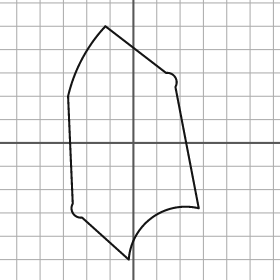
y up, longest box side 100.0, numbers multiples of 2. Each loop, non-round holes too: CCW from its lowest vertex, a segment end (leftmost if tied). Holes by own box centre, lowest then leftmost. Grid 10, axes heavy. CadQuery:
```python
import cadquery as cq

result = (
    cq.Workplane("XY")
    .moveTo(-2.0, -50.0)
    .threePointArc((8.0, -32.0), (28.0, -28.0))
    .lineTo(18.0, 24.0)
    .threePointArc((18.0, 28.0), (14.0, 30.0))
    .lineTo(-12.0, 50.0)
    .threePointArc((-22.0, 36.0), (-28.0, 20.0))
    .lineTo(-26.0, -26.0)
    .threePointArc((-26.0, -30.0), (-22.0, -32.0))
    .close()
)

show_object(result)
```